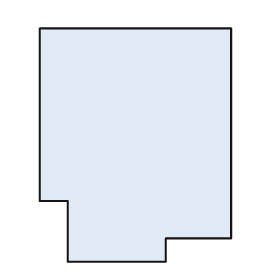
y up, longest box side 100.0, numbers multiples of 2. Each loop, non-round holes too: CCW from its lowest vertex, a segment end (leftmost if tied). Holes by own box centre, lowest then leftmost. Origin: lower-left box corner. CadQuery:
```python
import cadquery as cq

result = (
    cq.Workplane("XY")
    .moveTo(12.0, 0.0)
    .lineTo(54.0, 0.0)
    .lineTo(54.0, 10.0)
    .lineTo(82.0, 10.0)
    .lineTo(82.0, 100.0)
    .lineTo(0.0, 100.0)
    .lineTo(0.0, 26.0)
    .lineTo(12.0, 26.0)
    .close()
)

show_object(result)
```